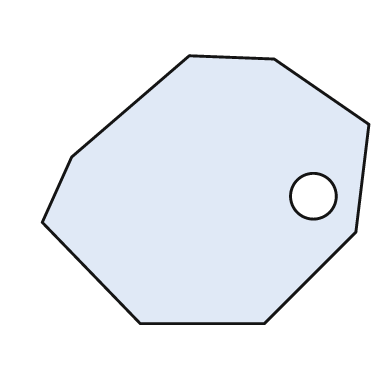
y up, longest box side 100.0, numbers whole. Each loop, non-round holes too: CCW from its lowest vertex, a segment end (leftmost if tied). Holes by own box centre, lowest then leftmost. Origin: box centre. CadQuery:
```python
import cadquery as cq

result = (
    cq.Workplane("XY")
    .moveTo(-20.0, -41.0)
    .lineTo(18.0, -41.0)
    .lineTo(46.0, -13.0)
    .lineTo(50.0, 20.0)
    .lineTo(21.0, 40.0)
    .lineTo(-5.0, 41.0)
    .lineTo(-41.0, 10.0)
    .lineTo(-50.0, -10.0)
    .close()
    .moveTo(33.0, -2.0)
    .circle(7.0)
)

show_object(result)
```